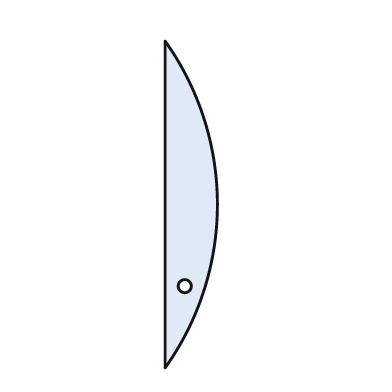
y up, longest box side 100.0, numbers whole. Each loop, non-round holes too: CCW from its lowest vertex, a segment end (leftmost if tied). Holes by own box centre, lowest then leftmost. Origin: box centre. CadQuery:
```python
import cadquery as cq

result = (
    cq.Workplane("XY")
    .moveTo(-8.0, -50.0)
    .threePointArc((8.0, 0.0), (-8.0, 50.0))
    .close()
    .moveTo(-2.0, -25.0)
    .circle(2.0)
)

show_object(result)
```